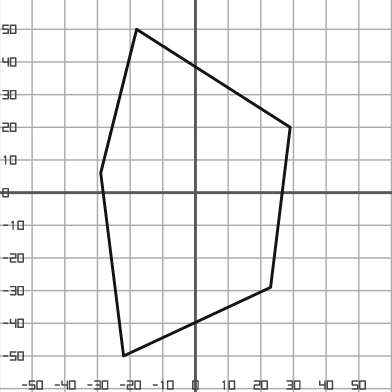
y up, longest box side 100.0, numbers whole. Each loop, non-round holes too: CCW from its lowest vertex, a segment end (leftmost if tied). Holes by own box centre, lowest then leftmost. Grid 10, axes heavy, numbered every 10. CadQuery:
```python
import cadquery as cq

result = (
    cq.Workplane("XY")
    .moveTo(-22.0, -50.0)
    .lineTo(23.0, -29.0)
    .lineTo(29.0, 20.0)
    .lineTo(-18.0, 50.0)
    .lineTo(-29.0, 6.0)
    .close()
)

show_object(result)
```